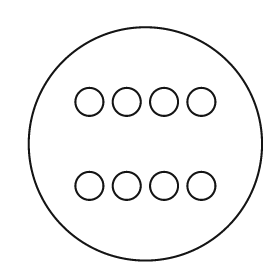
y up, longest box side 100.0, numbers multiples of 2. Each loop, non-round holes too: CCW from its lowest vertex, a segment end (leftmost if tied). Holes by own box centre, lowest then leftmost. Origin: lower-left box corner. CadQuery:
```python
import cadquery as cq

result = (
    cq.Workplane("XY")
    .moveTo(50.0, 50.0)
    .circle(50.0)
    .moveTo(26.0, 32.0)
    .circle(6.0)
    .moveTo(42.0, 32.0)
    .circle(6.0)
    .moveTo(58.0, 32.0)
    .circle(6.0)
    .moveTo(74.0, 32.0)
    .circle(6.0)
    .moveTo(26.0, 68.0)
    .circle(6.0)
    .moveTo(42.0, 68.0)
    .circle(6.0)
    .moveTo(58.0, 68.0)
    .circle(6.0)
    .moveTo(74.0, 68.0)
    .circle(6.0)
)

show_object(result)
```